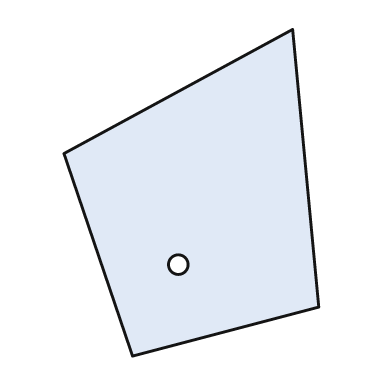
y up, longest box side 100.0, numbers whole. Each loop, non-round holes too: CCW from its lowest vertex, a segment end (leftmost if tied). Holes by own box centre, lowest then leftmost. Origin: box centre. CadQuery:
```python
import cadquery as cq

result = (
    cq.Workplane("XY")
    .moveTo(-18.0, -50.0)
    .lineTo(39.0, -35.0)
    .lineTo(31.0, 50.0)
    .lineTo(-39.0, 12.0)
    .close()
    .moveTo(-4.0, -22.0)
    .circle(3.0)
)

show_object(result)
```